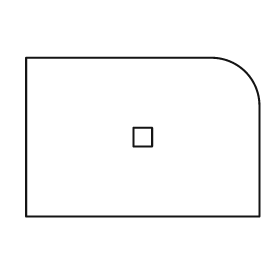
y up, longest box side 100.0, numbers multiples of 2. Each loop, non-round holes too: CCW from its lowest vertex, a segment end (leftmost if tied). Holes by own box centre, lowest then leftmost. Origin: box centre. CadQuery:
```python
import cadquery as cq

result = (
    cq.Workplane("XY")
    .moveTo(-50.0, -34.0)
    .lineTo(50.0, -34.0)
    .lineTo(50.0, 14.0)
    .threePointArc((44.0, 28.0), (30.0, 34.0))
    .lineTo(-50.0, 34.0)
    .close()
    .moveTo(-4.0, -4.0)
    .lineTo(4.0, -4.0)
    .lineTo(4.0, 4.0)
    .lineTo(-4.0, 4.0)
    .close()
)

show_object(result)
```